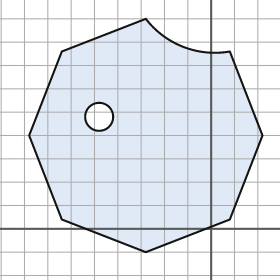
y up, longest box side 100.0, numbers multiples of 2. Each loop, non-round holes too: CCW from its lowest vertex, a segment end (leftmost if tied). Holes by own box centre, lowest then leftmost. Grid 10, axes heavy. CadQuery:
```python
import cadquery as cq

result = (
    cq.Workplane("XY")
    .moveTo(-28.0, -10.0)
    .lineTo(8.0, 4.0)
    .lineTo(22.0, 40.0)
    .lineTo(8.0, 76.0)
    .threePointArc((-12.0, 78.0), (-28.0, 90.0))
    .lineTo(-64.0, 76.0)
    .lineTo(-78.0, 40.0)
    .lineTo(-64.0, 4.0)
    .close()
    .moveTo(-48.0, 48.0)
    .circle(6.0)
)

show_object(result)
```